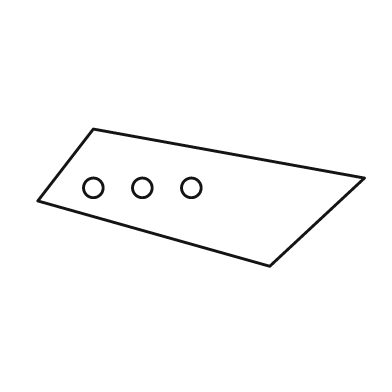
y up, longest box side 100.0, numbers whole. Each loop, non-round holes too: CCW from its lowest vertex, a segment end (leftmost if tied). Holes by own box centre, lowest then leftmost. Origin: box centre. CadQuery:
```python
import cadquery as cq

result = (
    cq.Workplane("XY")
    .moveTo(21.0, -21.0)
    .lineTo(50.0, 6.0)
    .lineTo(-33.0, 21.0)
    .lineTo(-50.0, -1.0)
    .close()
    .moveTo(-33.0, 3.0)
    .circle(3.0)
    .moveTo(-18.0, 3.0)
    .circle(3.0)
    .moveTo(-3.0, 3.0)
    .circle(3.0)
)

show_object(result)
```